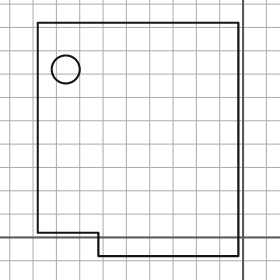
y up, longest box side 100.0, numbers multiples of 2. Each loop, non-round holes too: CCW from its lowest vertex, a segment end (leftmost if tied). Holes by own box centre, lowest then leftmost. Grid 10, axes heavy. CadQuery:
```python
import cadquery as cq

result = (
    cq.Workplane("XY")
    .moveTo(-62.0, -8.0)
    .lineTo(-2.0, -8.0)
    .lineTo(-2.0, 92.0)
    .lineTo(-88.0, 92.0)
    .lineTo(-88.0, 2.0)
    .lineTo(-62.0, 2.0)
    .close()
    .moveTo(-76.0, 72.0)
    .circle(6.0)
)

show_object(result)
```